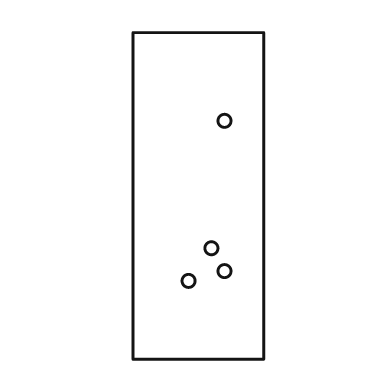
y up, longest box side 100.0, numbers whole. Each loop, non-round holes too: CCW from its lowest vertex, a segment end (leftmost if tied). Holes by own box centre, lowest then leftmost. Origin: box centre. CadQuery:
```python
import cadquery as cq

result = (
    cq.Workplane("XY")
    .moveTo(-20.0, -50.0)
    .lineTo(20.0, -50.0)
    .lineTo(20.0, 50.0)
    .lineTo(-20.0, 50.0)
    .close()
    .moveTo(-3.0, -26.0)
    .circle(2.0)
    .moveTo(8.0, -23.0)
    .circle(2.0)
    .moveTo(4.0, -16.0)
    .circle(2.0)
    .moveTo(8.0, 23.0)
    .circle(2.0)
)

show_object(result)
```